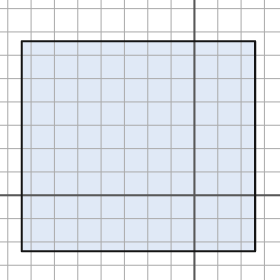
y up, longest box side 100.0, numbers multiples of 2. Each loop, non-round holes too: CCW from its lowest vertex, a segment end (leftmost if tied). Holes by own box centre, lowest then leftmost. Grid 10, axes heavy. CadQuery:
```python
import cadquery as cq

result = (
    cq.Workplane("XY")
    .moveTo(-74.0, -24.0)
    .lineTo(26.0, -24.0)
    .lineTo(26.0, 66.0)
    .lineTo(-74.0, 66.0)
    .close()
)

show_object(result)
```